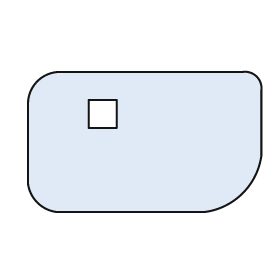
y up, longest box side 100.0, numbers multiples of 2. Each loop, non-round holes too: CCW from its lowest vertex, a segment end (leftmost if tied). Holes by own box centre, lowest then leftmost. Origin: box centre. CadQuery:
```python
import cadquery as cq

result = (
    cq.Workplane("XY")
    .moveTo(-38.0, -30.0)
    .lineTo(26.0, -30.0)
    .threePointArc((42.0, -22.0), (50.0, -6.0))
    .lineTo(50.0, 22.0)
    .threePointArc((48.0, 28.0), (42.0, 30.0))
    .lineTo(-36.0, 30.0)
    .threePointArc((-46.0, 26.0), (-50.0, 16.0))
    .lineTo(-50.0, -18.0)
    .threePointArc((-46.0, -26.0), (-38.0, -30.0))
    .close()
    .moveTo(-24.0, 6.0)
    .lineTo(-12.0, 6.0)
    .lineTo(-12.0, 18.0)
    .lineTo(-24.0, 18.0)
    .close()
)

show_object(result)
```